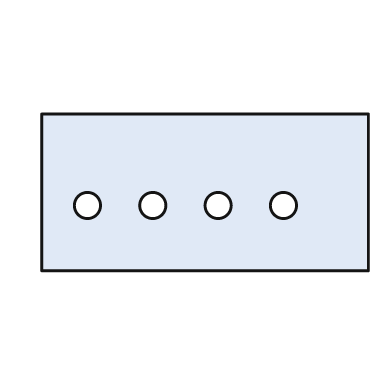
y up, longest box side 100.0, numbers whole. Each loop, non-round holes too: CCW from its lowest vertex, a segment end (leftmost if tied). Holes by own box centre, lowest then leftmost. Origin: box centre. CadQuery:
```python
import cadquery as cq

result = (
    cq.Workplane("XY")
    .moveTo(-50.0, -24.0)
    .lineTo(50.0, -24.0)
    .lineTo(50.0, 24.0)
    .lineTo(-50.0, 24.0)
    .close()
    .moveTo(-36.0, -4.0)
    .circle(4.0)
    .moveTo(-16.0, -4.0)
    .circle(4.0)
    .moveTo(4.0, -4.0)
    .circle(4.0)
    .moveTo(24.0, -4.0)
    .circle(4.0)
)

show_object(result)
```